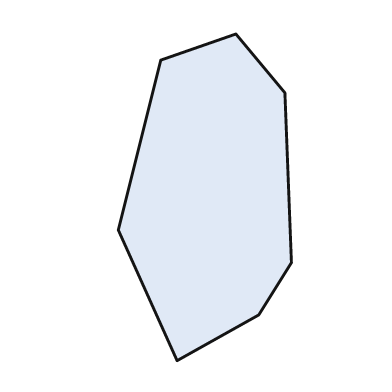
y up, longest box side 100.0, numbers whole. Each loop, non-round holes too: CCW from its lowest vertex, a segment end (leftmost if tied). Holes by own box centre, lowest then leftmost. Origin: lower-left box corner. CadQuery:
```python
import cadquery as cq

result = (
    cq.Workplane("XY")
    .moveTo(18.0, 0.0)
    .lineTo(43.0, 14.0)
    .lineTo(53.0, 30.0)
    .lineTo(51.0, 82.0)
    .lineTo(36.0, 100.0)
    .lineTo(13.0, 92.0)
    .lineTo(0.0, 40.0)
    .close()
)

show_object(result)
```